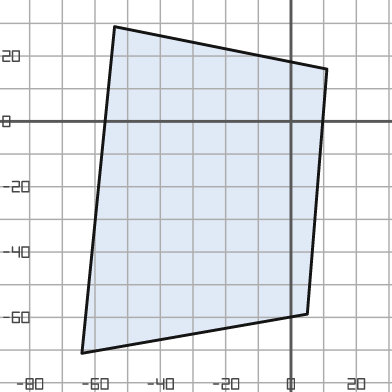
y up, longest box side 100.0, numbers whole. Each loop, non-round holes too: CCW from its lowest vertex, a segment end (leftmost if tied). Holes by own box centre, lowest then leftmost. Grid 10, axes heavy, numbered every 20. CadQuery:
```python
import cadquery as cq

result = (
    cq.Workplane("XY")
    .moveTo(-64.0, -71.0)
    .lineTo(5.0, -59.0)
    .lineTo(11.0, 16.0)
    .lineTo(-54.0, 29.0)
    .close()
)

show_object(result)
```